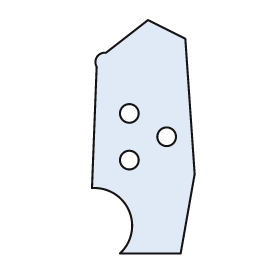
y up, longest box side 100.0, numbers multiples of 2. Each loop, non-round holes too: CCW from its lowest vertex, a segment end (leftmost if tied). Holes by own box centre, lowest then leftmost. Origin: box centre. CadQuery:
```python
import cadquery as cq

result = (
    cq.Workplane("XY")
    .moveTo(-10.0, -50.0)
    .lineTo(16.0, -50.0)
    .lineTo(22.0, -16.0)
    .lineTo(18.0, 42.0)
    .lineTo(2.0, 50.0)
    .lineTo(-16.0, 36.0)
    .threePointArc((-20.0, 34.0), (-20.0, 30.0))
    .lineTo(-22.0, -22.0)
    .threePointArc((-6.0, -32.0), (-10.0, -50.0))
    .close()
    .moveTo(-6.0, -10.0)
    .circle(4.0)
    .moveTo(10.0, 0.0)
    .circle(4.0)
    .moveTo(-6.0, 10.0)
    .circle(4.0)
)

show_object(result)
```